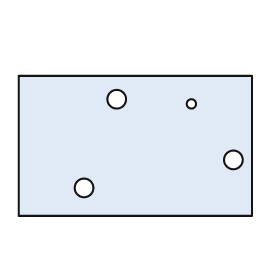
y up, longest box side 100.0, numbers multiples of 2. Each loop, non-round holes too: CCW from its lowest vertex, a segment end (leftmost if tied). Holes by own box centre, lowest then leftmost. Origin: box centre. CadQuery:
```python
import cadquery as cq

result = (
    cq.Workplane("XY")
    .moveTo(-50.0, -30.0)
    .lineTo(50.0, -30.0)
    .lineTo(50.0, 30.0)
    .lineTo(-50.0, 30.0)
    .close()
    .moveTo(-22.0, -18.0)
    .circle(4.0)
    .moveTo(42.0, -6.0)
    .circle(4.0)
    .moveTo(24.0, 18.0)
    .circle(2.0)
    .moveTo(-8.0, 20.0)
    .circle(4.0)
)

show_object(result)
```